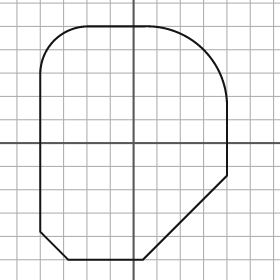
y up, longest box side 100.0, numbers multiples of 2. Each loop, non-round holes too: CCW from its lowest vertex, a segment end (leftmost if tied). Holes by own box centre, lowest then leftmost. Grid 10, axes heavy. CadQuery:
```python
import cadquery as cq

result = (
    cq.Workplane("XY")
    .moveTo(-28.0, -50.0)
    .lineTo(4.0, -50.0)
    .lineTo(40.0, -14.0)
    .lineTo(40.0, 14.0)
    .threePointArc((30.0, 40.0), (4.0, 50.0))
    .lineTo(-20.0, 50.0)
    .threePointArc((-34.0, 44.0), (-40.0, 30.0))
    .lineTo(-40.0, -38.0)
    .close()
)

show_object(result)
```